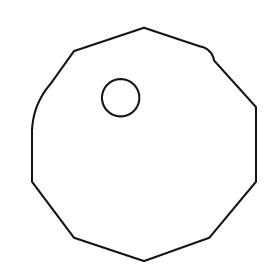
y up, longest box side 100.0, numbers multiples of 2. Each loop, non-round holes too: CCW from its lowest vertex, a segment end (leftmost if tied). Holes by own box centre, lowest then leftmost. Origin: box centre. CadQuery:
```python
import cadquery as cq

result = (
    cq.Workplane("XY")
    .moveTo(0.0, -50.0)
    .lineTo(28.0, -40.0)
    .lineTo(48.0, -16.0)
    .lineTo(48.0, 16.0)
    .lineTo(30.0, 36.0)
    .threePointArc((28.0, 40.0), (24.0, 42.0))
    .lineTo(0.0, 50.0)
    .lineTo(-30.0, 40.0)
    .lineTo(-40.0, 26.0)
    .threePointArc((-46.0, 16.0), (-48.0, 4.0))
    .lineTo(-48.0, -16.0)
    .lineTo(-30.0, -40.0)
    .close()
    .moveTo(-10.0, 20.0)
    .circle(8.0)
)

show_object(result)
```